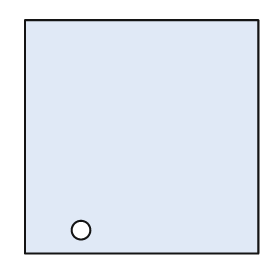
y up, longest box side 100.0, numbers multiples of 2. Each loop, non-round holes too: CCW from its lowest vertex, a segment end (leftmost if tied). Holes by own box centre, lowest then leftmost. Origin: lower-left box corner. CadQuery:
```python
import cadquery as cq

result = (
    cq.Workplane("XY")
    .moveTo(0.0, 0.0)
    .lineTo(100.0, 0.0)
    .lineTo(100.0, 100.0)
    .lineTo(0.0, 100.0)
    .close()
    .moveTo(24.0, 10.0)
    .circle(4.0)
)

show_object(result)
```